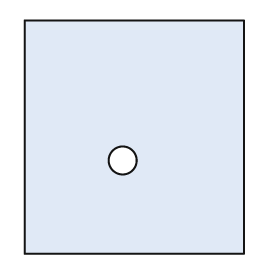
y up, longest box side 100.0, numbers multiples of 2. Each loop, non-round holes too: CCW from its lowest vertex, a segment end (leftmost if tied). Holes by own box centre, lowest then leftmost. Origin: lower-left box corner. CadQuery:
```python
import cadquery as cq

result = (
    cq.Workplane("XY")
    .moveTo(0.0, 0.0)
    .lineTo(94.0, 0.0)
    .lineTo(94.0, 100.0)
    .lineTo(0.0, 100.0)
    .close()
    .moveTo(42.0, 40.0)
    .circle(6.0)
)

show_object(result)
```